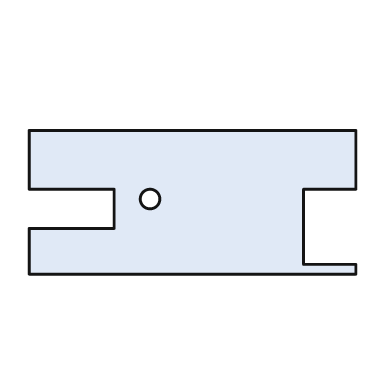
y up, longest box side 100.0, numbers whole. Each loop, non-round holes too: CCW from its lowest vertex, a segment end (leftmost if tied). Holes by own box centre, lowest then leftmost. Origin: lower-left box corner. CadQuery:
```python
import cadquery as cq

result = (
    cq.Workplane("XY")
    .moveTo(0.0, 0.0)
    .lineTo(100.0, 0.0)
    .lineTo(100.0, 3.0)
    .lineTo(84.0, 3.0)
    .lineTo(84.0, 26.0)
    .lineTo(100.0, 26.0)
    .lineTo(100.0, 44.0)
    .lineTo(0.0, 44.0)
    .lineTo(0.0, 26.0)
    .lineTo(26.0, 26.0)
    .lineTo(26.0, 14.0)
    .lineTo(0.0, 14.0)
    .close()
    .moveTo(37.0, 23.0)
    .circle(3.0)
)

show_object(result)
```